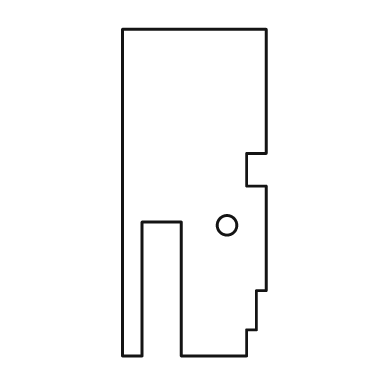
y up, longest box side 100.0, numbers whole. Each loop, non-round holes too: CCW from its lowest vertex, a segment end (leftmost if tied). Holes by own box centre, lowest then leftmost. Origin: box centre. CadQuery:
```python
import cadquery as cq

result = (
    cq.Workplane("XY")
    .moveTo(-22.0, -50.0)
    .lineTo(-16.0, -50.0)
    .lineTo(-16.0, -9.0)
    .lineTo(-4.0, -9.0)
    .lineTo(-4.0, -50.0)
    .lineTo(16.0, -50.0)
    .lineTo(16.0, -42.0)
    .lineTo(19.0, -42.0)
    .lineTo(19.0, -30.0)
    .lineTo(22.0, -30.0)
    .lineTo(22.0, 2.0)
    .lineTo(16.0, 2.0)
    .lineTo(16.0, 12.0)
    .lineTo(22.0, 12.0)
    .lineTo(22.0, 50.0)
    .lineTo(-22.0, 50.0)
    .close()
    .moveTo(10.0, -10.0)
    .circle(3.0)
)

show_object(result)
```